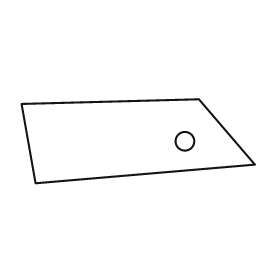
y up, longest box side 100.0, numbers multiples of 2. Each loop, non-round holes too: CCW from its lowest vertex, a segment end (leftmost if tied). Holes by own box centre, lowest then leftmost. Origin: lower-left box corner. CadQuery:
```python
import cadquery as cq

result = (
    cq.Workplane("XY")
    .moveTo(6.0, 0.0)
    .lineTo(100.0, 8.0)
    .lineTo(76.0, 36.0)
    .lineTo(0.0, 34.0)
    .close()
    .moveTo(70.0, 18.0)
    .circle(4.0)
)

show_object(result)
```